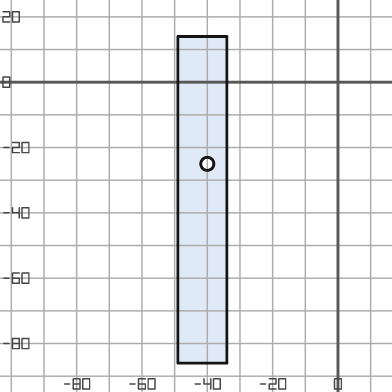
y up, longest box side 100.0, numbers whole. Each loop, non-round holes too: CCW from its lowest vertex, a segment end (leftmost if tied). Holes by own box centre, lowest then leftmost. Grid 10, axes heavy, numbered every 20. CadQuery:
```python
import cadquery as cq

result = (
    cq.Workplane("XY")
    .moveTo(-49.0, -86.0)
    .lineTo(-34.0, -86.0)
    .lineTo(-34.0, 14.0)
    .lineTo(-49.0, 14.0)
    .close()
    .moveTo(-40.0, -25.0)
    .circle(2.0)
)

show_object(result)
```